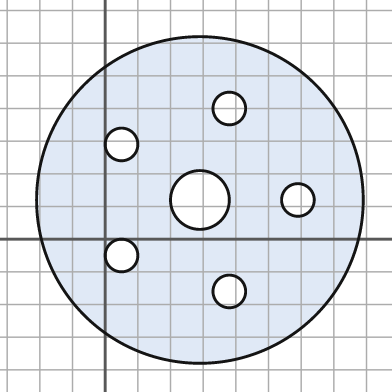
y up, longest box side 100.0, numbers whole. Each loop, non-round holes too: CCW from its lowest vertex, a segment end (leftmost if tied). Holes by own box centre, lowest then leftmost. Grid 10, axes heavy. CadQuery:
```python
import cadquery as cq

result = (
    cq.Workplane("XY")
    .moveTo(29.0, 12.0)
    .circle(50.0)
    .moveTo(38.0, -16.0)
    .circle(5.0)
    .moveTo(5.0, -5.0)
    .circle(5.0)
    .moveTo(29.0, 12.0)
    .circle(9.0)
    .moveTo(59.0, 12.0)
    .circle(5.0)
    .moveTo(5.0, 29.0)
    .circle(5.0)
    .moveTo(38.0, 40.0)
    .circle(5.0)
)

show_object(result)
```